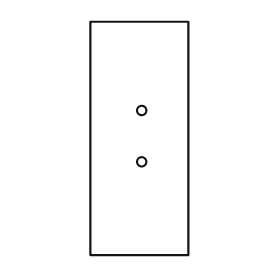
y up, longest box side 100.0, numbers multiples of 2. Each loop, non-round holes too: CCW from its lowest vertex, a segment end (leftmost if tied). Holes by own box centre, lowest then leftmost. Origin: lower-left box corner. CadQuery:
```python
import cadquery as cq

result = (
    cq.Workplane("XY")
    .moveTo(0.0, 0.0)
    .lineTo(42.0, 0.0)
    .lineTo(42.0, 100.0)
    .lineTo(0.0, 100.0)
    .close()
    .moveTo(22.0, 40.0)
    .circle(2.0)
    .moveTo(22.0, 62.0)
    .circle(2.0)
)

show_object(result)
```